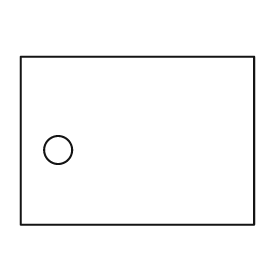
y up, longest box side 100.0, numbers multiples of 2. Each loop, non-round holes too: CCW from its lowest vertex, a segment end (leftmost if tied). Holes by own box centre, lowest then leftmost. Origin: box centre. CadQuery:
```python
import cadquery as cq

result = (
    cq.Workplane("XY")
    .moveTo(-50.0, -36.0)
    .lineTo(50.0, -36.0)
    .lineTo(50.0, 36.0)
    .lineTo(-50.0, 36.0)
    .close()
    .moveTo(-34.0, -4.0)
    .circle(6.0)
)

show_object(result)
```